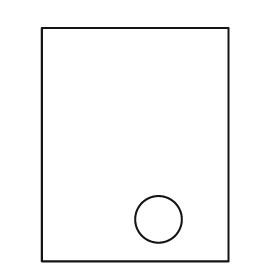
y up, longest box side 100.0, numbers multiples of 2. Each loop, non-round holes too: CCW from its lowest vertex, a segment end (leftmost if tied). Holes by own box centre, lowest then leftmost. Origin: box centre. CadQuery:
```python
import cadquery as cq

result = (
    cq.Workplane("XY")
    .moveTo(-40.0, -50.0)
    .lineTo(40.0, -50.0)
    .lineTo(40.0, 50.0)
    .lineTo(-40.0, 50.0)
    .close()
    .moveTo(10.0, -32.0)
    .circle(10.0)
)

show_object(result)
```